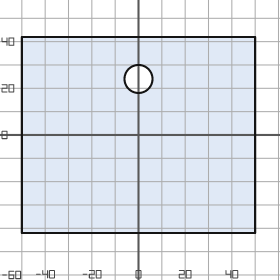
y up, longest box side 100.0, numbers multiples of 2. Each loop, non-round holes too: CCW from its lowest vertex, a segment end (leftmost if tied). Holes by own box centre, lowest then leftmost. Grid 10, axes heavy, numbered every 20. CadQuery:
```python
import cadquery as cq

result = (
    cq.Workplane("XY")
    .moveTo(-50.0, -42.0)
    .lineTo(50.0, -42.0)
    .lineTo(50.0, 42.0)
    .lineTo(-50.0, 42.0)
    .close()
    .moveTo(0.0, 24.0)
    .circle(6.0)
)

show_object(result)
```